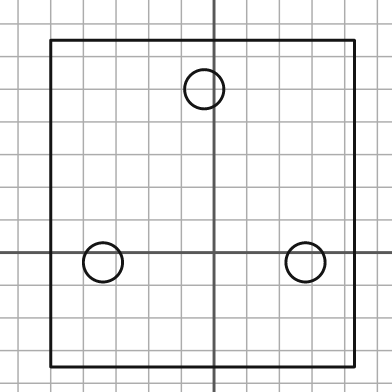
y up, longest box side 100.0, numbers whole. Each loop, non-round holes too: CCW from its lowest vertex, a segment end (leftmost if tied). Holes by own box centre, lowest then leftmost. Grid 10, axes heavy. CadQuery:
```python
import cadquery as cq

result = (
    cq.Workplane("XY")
    .moveTo(-50.0, -35.0)
    .lineTo(43.0, -35.0)
    .lineTo(43.0, 65.0)
    .lineTo(-50.0, 65.0)
    .close()
    .moveTo(-34.0, -3.0)
    .circle(6.0)
    .moveTo(28.0, -3.0)
    .circle(6.0)
    .moveTo(-3.0, 50.0)
    .circle(6.0)
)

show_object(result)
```